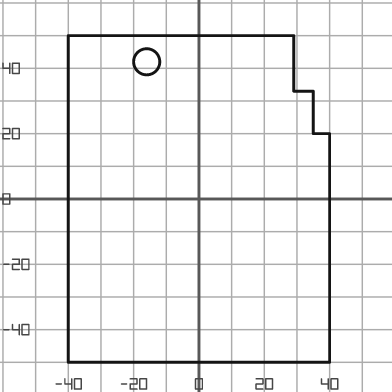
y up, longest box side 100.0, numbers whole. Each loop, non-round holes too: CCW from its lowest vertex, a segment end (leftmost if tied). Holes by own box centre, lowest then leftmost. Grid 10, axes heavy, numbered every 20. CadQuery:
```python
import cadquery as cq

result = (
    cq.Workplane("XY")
    .moveTo(-40.0, -50.0)
    .lineTo(40.0, -50.0)
    .lineTo(40.0, 20.0)
    .lineTo(35.0, 20.0)
    .lineTo(35.0, 33.0)
    .lineTo(29.0, 33.0)
    .lineTo(29.0, 50.0)
    .lineTo(-40.0, 50.0)
    .close()
    .moveTo(-16.0, 42.0)
    .circle(4.0)
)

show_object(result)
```